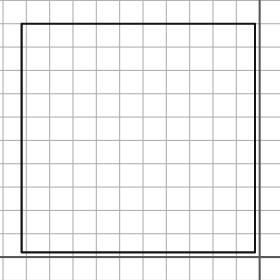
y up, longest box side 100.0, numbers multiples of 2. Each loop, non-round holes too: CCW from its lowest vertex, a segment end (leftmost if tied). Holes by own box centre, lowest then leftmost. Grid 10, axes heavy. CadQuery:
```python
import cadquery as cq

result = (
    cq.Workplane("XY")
    .moveTo(-102.0, 2.0)
    .lineTo(-2.0, 2.0)
    .lineTo(-2.0, 100.0)
    .lineTo(-102.0, 100.0)
    .close()
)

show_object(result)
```